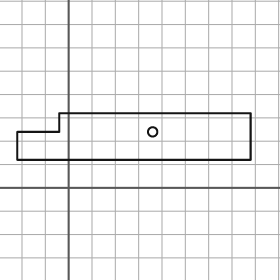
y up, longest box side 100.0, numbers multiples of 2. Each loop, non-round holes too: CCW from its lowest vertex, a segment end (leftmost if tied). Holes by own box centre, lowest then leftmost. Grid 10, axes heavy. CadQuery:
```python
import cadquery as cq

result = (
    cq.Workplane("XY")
    .moveTo(-22.0, 12.0)
    .lineTo(78.0, 12.0)
    .lineTo(78.0, 32.0)
    .lineTo(-4.0, 32.0)
    .lineTo(-4.0, 24.0)
    .lineTo(-22.0, 24.0)
    .close()
    .moveTo(36.0, 24.0)
    .circle(2.0)
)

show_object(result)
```